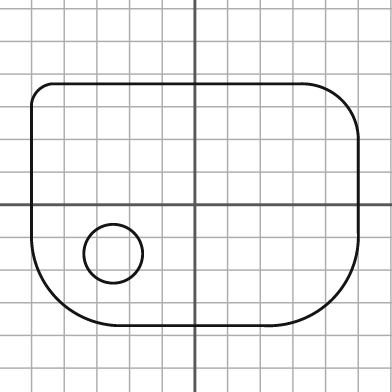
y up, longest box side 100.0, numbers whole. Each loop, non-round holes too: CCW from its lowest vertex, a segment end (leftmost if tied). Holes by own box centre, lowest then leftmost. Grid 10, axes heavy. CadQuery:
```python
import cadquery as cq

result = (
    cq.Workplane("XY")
    .moveTo(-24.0, -37.0)
    .lineTo(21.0, -37.0)
    .threePointArc((42.0, -29.0), (50.0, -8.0))
    .lineTo(50.0, 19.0)
    .threePointArc((45.0, 32.0), (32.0, 37.0))
    .lineTo(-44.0, 37.0)
    .threePointArc((-48.0, 35.0), (-50.0, 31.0))
    .lineTo(-50.0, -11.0)
    .threePointArc((-42.0, -29.0), (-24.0, -37.0))
    .close()
    .moveTo(-25.0, -15.0)
    .circle(9.0)
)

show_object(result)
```